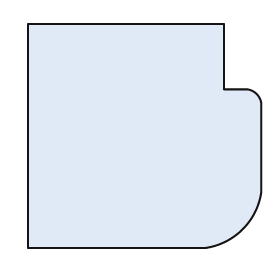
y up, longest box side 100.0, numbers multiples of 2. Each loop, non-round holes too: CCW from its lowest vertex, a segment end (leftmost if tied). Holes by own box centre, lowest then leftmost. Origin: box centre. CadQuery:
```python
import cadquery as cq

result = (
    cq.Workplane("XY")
    .moveTo(-50.0, -48.0)
    .lineTo(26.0, -48.0)
    .threePointArc((42.0, -40.0), (50.0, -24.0))
    .lineTo(50.0, 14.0)
    .threePointArc((48.0, 18.0), (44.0, 20.0))
    .lineTo(34.0, 20.0)
    .lineTo(34.0, 48.0)
    .lineTo(-50.0, 48.0)
    .close()
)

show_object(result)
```